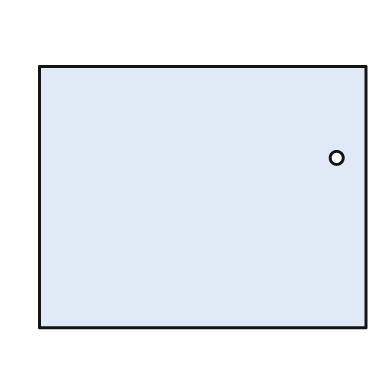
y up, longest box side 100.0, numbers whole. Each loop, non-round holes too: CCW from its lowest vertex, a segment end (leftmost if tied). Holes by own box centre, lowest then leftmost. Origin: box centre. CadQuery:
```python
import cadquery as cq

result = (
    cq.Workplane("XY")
    .moveTo(-50.0, -40.0)
    .lineTo(50.0, -40.0)
    .lineTo(50.0, 40.0)
    .lineTo(-50.0, 40.0)
    .close()
    .moveTo(41.0, 12.0)
    .circle(2.0)
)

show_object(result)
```